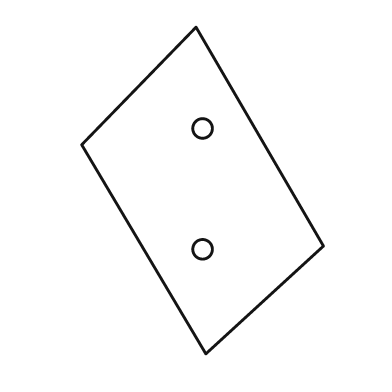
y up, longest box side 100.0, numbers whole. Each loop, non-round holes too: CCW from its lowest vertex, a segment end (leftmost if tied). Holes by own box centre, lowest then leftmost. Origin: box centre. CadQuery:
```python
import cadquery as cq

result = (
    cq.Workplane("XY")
    .moveTo(1.0, -50.0)
    .lineTo(37.0, -17.0)
    .lineTo(-2.0, 50.0)
    .lineTo(-37.0, 14.0)
    .close()
    .moveTo(0.0, -18.0)
    .circle(3.0)
    .moveTo(0.0, 19.0)
    .circle(3.0)
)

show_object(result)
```